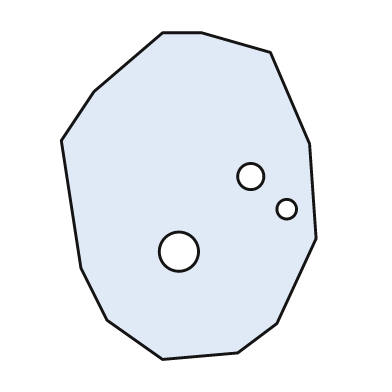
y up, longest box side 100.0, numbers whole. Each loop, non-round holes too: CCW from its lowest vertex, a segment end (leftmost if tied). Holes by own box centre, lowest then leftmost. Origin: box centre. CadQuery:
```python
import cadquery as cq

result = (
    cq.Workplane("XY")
    .moveTo(-8.0, -50.0)
    .lineTo(15.0, -48.0)
    .lineTo(27.0, -39.0)
    .lineTo(39.0, -13.0)
    .lineTo(37.0, 16.0)
    .lineTo(25.0, 44.0)
    .lineTo(4.0, 50.0)
    .lineTo(-8.0, 50.0)
    .lineTo(-29.0, 32.0)
    .lineTo(-39.0, 17.0)
    .lineTo(-33.0, -22.0)
    .lineTo(-25.0, -38.0)
    .close()
    .moveTo(-3.0, -17.0)
    .circle(6.0)
    .moveTo(30.0, -4.0)
    .circle(3.0)
    .moveTo(19.0, 6.0)
    .circle(4.0)
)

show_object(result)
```